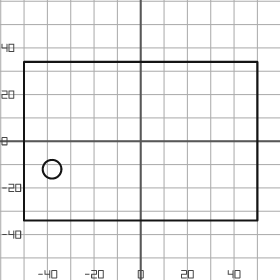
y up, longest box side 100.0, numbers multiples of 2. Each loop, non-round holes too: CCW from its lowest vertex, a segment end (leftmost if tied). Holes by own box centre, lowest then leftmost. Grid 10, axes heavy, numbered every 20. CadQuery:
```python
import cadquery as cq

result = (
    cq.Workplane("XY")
    .moveTo(-50.0, -34.0)
    .lineTo(50.0, -34.0)
    .lineTo(50.0, 34.0)
    .lineTo(-50.0, 34.0)
    .close()
    .moveTo(-38.0, -12.0)
    .circle(4.0)
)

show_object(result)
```